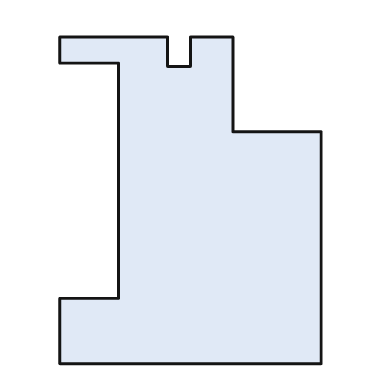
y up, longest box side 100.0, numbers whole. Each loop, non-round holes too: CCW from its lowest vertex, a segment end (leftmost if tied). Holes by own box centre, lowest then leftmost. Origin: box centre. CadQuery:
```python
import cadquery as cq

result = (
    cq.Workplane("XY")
    .moveTo(-40.0, -50.0)
    .lineTo(40.0, -50.0)
    .lineTo(40.0, 21.0)
    .lineTo(13.0, 21.0)
    .lineTo(13.0, 50.0)
    .lineTo(0.0, 50.0)
    .lineTo(0.0, 41.0)
    .lineTo(-7.0, 41.0)
    .lineTo(-7.0, 50.0)
    .lineTo(-40.0, 50.0)
    .lineTo(-40.0, 42.0)
    .lineTo(-22.0, 42.0)
    .lineTo(-22.0, -30.0)
    .lineTo(-40.0, -30.0)
    .close()
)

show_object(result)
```